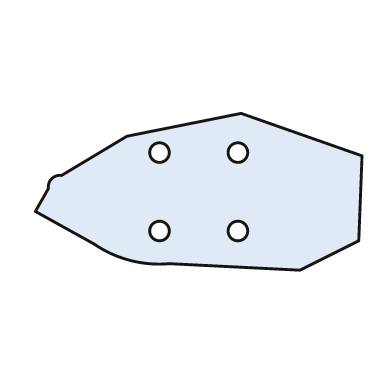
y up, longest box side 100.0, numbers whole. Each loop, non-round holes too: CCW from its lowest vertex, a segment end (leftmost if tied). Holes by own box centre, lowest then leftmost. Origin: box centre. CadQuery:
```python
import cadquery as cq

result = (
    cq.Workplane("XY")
    .moveTo(31.0, -24.0)
    .lineTo(49.0, -15.0)
    .lineTo(50.0, 11.0)
    .lineTo(13.0, 24.0)
    .lineTo(-22.0, 17.0)
    .lineTo(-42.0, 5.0)
    .threePointArc((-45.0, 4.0), (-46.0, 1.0))
    .lineTo(-50.0, -6.0)
    .lineTo(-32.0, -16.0)
    .threePointArc((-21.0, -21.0), (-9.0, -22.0))
    .close()
    .moveTo(-12.0, -12.0)
    .circle(3.0)
    .moveTo(12.0, -12.0)
    .circle(3.0)
    .moveTo(-12.0, 12.0)
    .circle(3.0)
    .moveTo(12.0, 12.0)
    .circle(3.0)
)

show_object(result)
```